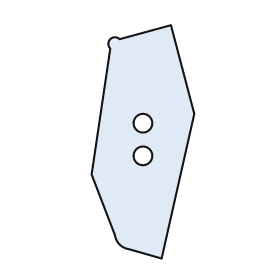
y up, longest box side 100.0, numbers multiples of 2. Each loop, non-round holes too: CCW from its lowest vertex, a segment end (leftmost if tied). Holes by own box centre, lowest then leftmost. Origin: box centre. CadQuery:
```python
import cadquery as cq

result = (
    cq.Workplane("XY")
    .moveTo(8.0, -50.0)
    .lineTo(22.0, 12.0)
    .lineTo(12.0, 50.0)
    .lineTo(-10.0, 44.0)
    .threePointArc((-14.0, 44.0), (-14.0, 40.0))
    .lineTo(-22.0, -14.0)
    .lineTo(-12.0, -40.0)
    .threePointArc((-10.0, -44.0), (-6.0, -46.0))
    .close()
    .moveTo(0.0, -6.0)
    .circle(4.0)
    .moveTo(0.0, 8.0)
    .circle(4.0)
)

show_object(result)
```